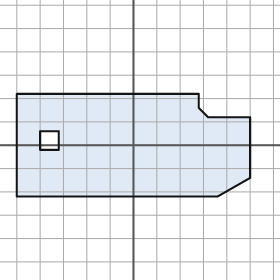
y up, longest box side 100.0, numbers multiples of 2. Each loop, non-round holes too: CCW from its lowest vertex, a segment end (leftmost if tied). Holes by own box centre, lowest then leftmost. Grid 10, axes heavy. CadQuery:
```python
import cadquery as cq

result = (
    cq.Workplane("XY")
    .moveTo(-50.0, -22.0)
    .lineTo(36.0, -22.0)
    .lineTo(50.0, -14.0)
    .lineTo(50.0, 12.0)
    .lineTo(32.0, 12.0)
    .lineTo(28.0, 16.0)
    .lineTo(28.0, 22.0)
    .lineTo(-50.0, 22.0)
    .close()
    .moveTo(-40.0, -2.0)
    .lineTo(-32.0, -2.0)
    .lineTo(-32.0, 6.0)
    .lineTo(-40.0, 6.0)
    .close()
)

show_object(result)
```